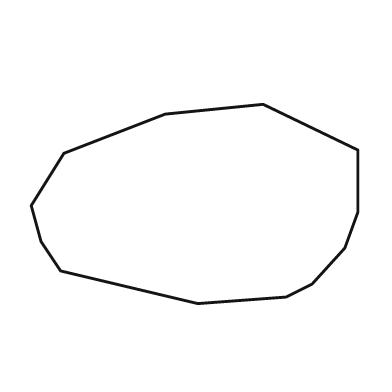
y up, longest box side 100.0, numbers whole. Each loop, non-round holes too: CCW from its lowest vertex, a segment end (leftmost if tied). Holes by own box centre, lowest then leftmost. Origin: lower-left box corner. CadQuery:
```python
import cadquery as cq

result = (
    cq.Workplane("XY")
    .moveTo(51.0, 0.0)
    .lineTo(78.0, 2.0)
    .lineTo(86.0, 6.0)
    .lineTo(96.0, 17.0)
    .lineTo(100.0, 28.0)
    .lineTo(100.0, 47.0)
    .lineTo(71.0, 61.0)
    .lineTo(41.0, 58.0)
    .lineTo(10.0, 46.0)
    .lineTo(0.0, 30.0)
    .lineTo(3.0, 19.0)
    .lineTo(9.0, 10.0)
    .close()
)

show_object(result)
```